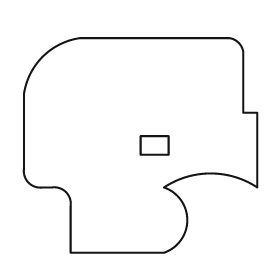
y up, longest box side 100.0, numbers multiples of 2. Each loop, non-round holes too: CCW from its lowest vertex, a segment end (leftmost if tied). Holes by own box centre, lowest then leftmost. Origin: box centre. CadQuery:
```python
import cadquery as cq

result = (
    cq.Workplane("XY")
    .moveTo(-30.0, -46.0)
    .lineTo(10.0, -46.0)
    .threePointArc((20.0, -32.0), (10.0, -18.0))
    .threePointArc((30.0, -12.0), (50.0, -18.0))
    .lineTo(50.0, 14.0)
    .lineTo(44.0, 14.0)
    .lineTo(44.0, 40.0)
    .threePointArc((42.0, 44.0), (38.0, 46.0))
    .lineTo(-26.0, 46.0)
    .threePointArc((-42.0, 38.0), (-50.0, 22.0))
    .lineTo(-50.0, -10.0)
    .threePointArc((-48.0, -16.0), (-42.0, -18.0))
    .lineTo(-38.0, -18.0)
    .threePointArc((-32.0, -20.0), (-30.0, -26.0))
    .close()
    .moveTo(0.0, -4.0)
    .lineTo(12.0, -4.0)
    .lineTo(12.0, 4.0)
    .lineTo(0.0, 4.0)
    .close()
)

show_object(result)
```